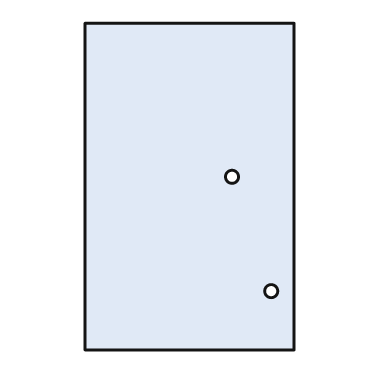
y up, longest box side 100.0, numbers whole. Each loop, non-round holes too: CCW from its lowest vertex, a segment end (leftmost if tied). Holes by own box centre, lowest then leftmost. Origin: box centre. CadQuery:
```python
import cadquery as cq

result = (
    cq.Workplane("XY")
    .moveTo(-32.0, -50.0)
    .lineTo(32.0, -50.0)
    .lineTo(32.0, 50.0)
    .lineTo(-32.0, 50.0)
    .close()
    .moveTo(25.0, -32.0)
    .circle(2.0)
    .moveTo(13.0, 3.0)
    .circle(2.0)
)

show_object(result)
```